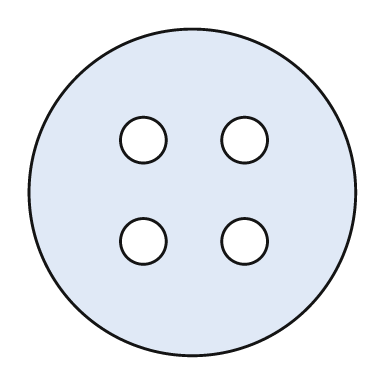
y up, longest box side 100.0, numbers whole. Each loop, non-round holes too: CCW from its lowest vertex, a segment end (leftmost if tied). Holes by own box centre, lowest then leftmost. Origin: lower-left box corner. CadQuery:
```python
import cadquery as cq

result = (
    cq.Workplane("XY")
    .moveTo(50.0, 50.0)
    .circle(50.0)
    .moveTo(35.0, 35.0)
    .circle(7.0)
    .moveTo(66.0, 35.0)
    .circle(7.0)
    .moveTo(35.0, 66.0)
    .circle(7.0)
    .moveTo(66.0, 66.0)
    .circle(7.0)
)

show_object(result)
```